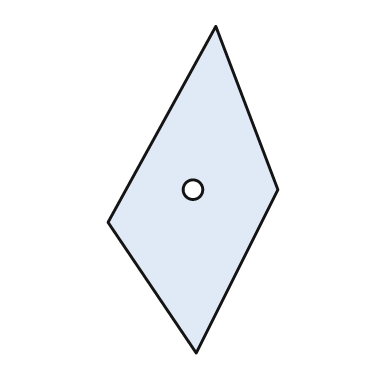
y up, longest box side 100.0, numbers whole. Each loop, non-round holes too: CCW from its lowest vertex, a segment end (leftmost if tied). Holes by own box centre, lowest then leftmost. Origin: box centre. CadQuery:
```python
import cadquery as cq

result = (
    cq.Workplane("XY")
    .moveTo(1.0, -50.0)
    .lineTo(26.0, 0.0)
    .lineTo(7.0, 50.0)
    .lineTo(-26.0, -10.0)
    .close()
    .moveTo(0.0, 0.0)
    .circle(3.0)
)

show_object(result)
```